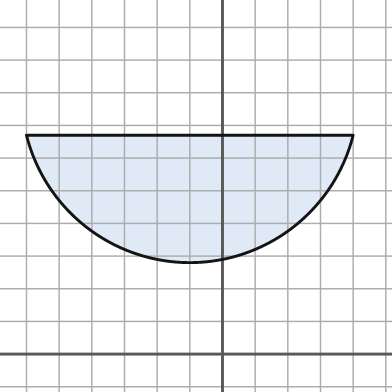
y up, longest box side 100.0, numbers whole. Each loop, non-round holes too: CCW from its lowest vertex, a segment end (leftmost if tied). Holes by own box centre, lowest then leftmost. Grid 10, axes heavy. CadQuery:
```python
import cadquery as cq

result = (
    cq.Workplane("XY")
    .moveTo(-60.0, 67.0)
    .threePointArc((-10.0, 28.0), (40.0, 67.0))
    .close()
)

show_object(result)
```